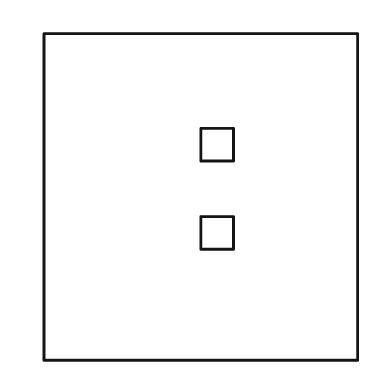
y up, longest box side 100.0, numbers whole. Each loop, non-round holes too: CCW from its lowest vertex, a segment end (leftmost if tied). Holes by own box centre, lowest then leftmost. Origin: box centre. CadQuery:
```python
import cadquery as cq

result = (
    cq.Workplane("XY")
    .moveTo(-48.0, -50.0)
    .lineTo(48.0, -50.0)
    .lineTo(48.0, 50.0)
    .lineTo(-48.0, 50.0)
    .close()
    .moveTo(0.0, -16.0)
    .lineTo(10.0, -16.0)
    .lineTo(10.0, -6.0)
    .lineTo(0.0, -6.0)
    .close()
    .moveTo(0.0, 11.0)
    .lineTo(10.0, 11.0)
    .lineTo(10.0, 21.0)
    .lineTo(0.0, 21.0)
    .close()
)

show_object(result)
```